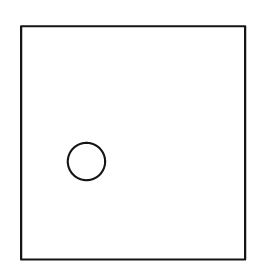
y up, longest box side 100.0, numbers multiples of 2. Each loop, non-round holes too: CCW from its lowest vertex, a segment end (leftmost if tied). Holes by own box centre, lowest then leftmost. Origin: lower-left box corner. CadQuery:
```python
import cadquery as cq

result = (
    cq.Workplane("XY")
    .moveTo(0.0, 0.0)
    .lineTo(96.0, 0.0)
    .lineTo(96.0, 100.0)
    .lineTo(0.0, 100.0)
    .close()
    .moveTo(28.0, 42.0)
    .circle(8.0)
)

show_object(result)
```